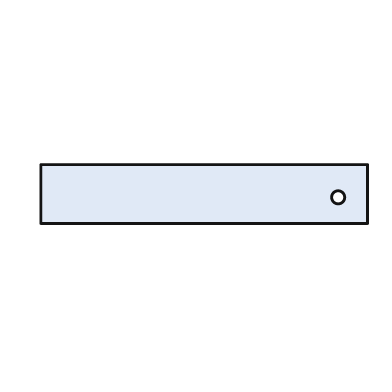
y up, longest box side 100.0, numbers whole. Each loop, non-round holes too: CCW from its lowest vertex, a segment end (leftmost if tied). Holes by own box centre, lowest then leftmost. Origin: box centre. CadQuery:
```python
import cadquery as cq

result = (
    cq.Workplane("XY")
    .moveTo(-50.0, -9.0)
    .lineTo(50.0, -9.0)
    .lineTo(50.0, 9.0)
    .lineTo(-50.0, 9.0)
    .close()
    .moveTo(41.0, -1.0)
    .circle(2.0)
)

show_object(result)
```